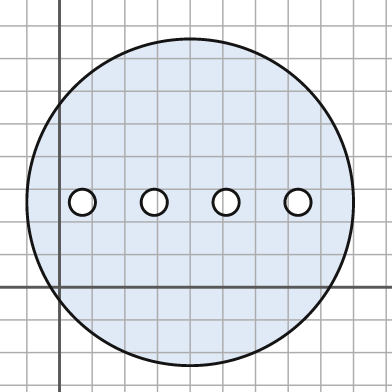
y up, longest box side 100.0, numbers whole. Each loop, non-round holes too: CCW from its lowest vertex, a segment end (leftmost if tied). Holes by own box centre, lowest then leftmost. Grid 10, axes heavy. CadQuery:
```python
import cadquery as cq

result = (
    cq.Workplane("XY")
    .moveTo(40.0, 26.0)
    .circle(50.0)
    .moveTo(7.0, 26.0)
    .circle(4.0)
    .moveTo(29.0, 26.0)
    .circle(4.0)
    .moveTo(51.0, 26.0)
    .circle(4.0)
    .moveTo(73.0, 26.0)
    .circle(4.0)
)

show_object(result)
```